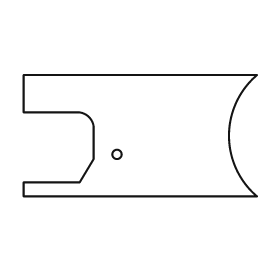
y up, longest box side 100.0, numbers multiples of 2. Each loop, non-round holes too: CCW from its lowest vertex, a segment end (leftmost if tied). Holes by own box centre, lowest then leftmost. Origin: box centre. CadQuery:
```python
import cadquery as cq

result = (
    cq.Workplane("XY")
    .moveTo(-50.0, -26.0)
    .lineTo(50.0, -26.0)
    .threePointArc((38.0, 0.0), (50.0, 26.0))
    .lineTo(-50.0, 26.0)
    .lineTo(-50.0, 10.0)
    .lineTo(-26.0, 10.0)
    .threePointArc((-22.0, 8.0), (-20.0, 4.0))
    .lineTo(-20.0, -10.0)
    .lineTo(-26.0, -20.0)
    .lineTo(-50.0, -20.0)
    .close()
    .moveTo(-10.0, -8.0)
    .circle(2.0)
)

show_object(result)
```